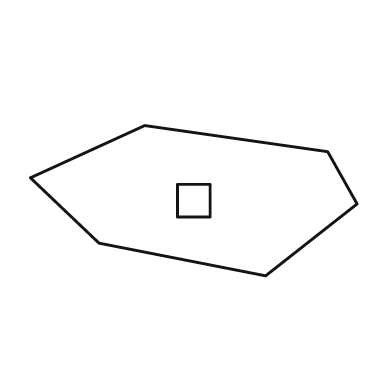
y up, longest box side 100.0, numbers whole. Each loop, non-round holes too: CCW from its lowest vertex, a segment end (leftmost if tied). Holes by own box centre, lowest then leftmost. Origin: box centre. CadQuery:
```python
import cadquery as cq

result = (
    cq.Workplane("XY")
    .moveTo(22.0, -23.0)
    .lineTo(50.0, -1.0)
    .lineTo(41.0, 15.0)
    .lineTo(-15.0, 23.0)
    .lineTo(-50.0, 7.0)
    .lineTo(-29.0, -13.0)
    .close()
    .moveTo(-5.0, -5.0)
    .lineTo(5.0, -5.0)
    .lineTo(5.0, 5.0)
    .lineTo(-5.0, 5.0)
    .close()
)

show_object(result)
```